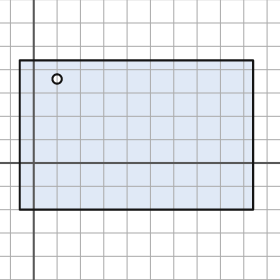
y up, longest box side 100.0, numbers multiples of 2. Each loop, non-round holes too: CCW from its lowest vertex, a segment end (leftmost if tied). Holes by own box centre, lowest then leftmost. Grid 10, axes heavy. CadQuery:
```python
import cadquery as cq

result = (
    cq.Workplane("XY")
    .moveTo(-6.0, -20.0)
    .lineTo(94.0, -20.0)
    .lineTo(94.0, 44.0)
    .lineTo(-6.0, 44.0)
    .close()
    .moveTo(10.0, 36.0)
    .circle(2.0)
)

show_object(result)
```